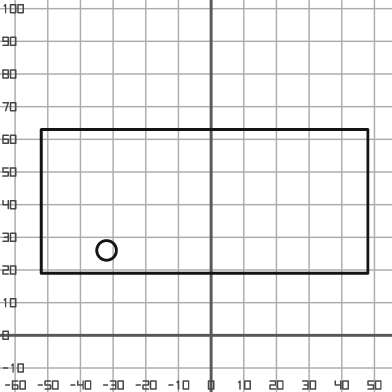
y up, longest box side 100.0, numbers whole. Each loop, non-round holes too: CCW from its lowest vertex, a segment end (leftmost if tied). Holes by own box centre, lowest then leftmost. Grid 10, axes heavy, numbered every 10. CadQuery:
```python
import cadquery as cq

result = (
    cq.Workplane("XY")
    .moveTo(-52.0, 19.0)
    .lineTo(48.0, 19.0)
    .lineTo(48.0, 63.0)
    .lineTo(-52.0, 63.0)
    .close()
    .moveTo(-32.0, 26.0)
    .circle(3.0)
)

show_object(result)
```